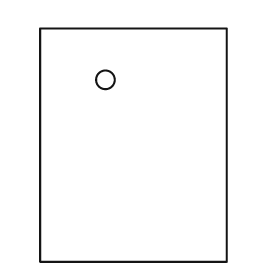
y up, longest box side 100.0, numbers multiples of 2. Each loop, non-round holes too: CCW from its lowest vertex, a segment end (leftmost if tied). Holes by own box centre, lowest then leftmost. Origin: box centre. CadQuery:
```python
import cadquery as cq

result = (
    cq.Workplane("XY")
    .moveTo(-40.0, -50.0)
    .lineTo(40.0, -50.0)
    .lineTo(40.0, 50.0)
    .lineTo(-40.0, 50.0)
    .close()
    .moveTo(-12.0, 28.0)
    .circle(4.0)
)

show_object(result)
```